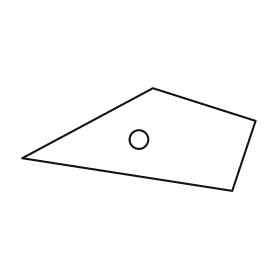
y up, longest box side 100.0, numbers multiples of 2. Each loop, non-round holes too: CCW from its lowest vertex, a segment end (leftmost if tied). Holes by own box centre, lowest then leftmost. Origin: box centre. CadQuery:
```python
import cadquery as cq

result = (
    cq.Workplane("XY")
    .moveTo(40.0, -22.0)
    .lineTo(50.0, 8.0)
    .lineTo(6.0, 22.0)
    .lineTo(-50.0, -8.0)
    .close()
    .moveTo(0.0, 0.0)
    .circle(4.0)
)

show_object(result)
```